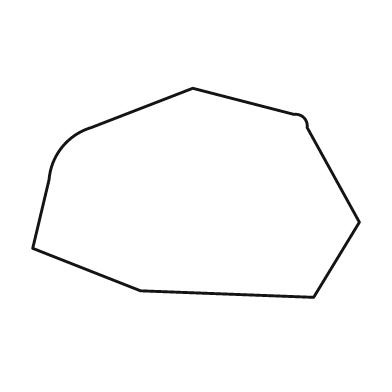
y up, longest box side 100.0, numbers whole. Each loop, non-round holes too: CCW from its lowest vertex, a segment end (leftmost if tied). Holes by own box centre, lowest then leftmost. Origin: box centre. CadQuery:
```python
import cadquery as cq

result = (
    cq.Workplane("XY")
    .moveTo(36.0, -32.0)
    .lineTo(50.0, -9.0)
    .lineTo(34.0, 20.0)
    .threePointArc((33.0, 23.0), (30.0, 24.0))
    .lineTo(-1.0, 32.0)
    .lineTo(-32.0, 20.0)
    .threePointArc((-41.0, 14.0), (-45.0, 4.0))
    .lineTo(-50.0, -17.0)
    .lineTo(-17.0, -30.0)
    .close()
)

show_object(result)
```